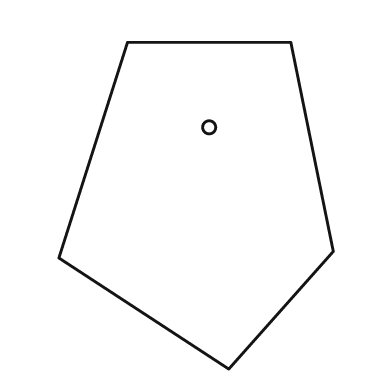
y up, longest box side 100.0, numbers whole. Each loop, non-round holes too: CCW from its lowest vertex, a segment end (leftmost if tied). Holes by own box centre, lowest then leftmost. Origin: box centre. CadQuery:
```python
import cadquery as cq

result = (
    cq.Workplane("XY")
    .moveTo(10.0, -50.0)
    .lineTo(42.0, -14.0)
    .lineTo(29.0, 50.0)
    .lineTo(-21.0, 50.0)
    .lineTo(-42.0, -16.0)
    .close()
    .moveTo(4.0, 24.0)
    .circle(2.0)
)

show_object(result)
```